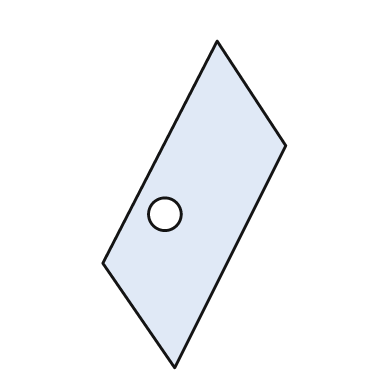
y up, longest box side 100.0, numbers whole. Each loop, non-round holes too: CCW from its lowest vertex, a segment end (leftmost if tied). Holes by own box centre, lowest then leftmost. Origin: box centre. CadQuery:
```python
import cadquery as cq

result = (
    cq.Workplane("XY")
    .moveTo(-6.0, -50.0)
    .lineTo(28.0, 18.0)
    .lineTo(7.0, 50.0)
    .lineTo(-28.0, -18.0)
    .close()
    .moveTo(-9.0, -3.0)
    .circle(5.0)
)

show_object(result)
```